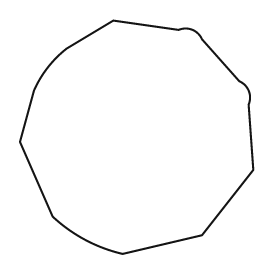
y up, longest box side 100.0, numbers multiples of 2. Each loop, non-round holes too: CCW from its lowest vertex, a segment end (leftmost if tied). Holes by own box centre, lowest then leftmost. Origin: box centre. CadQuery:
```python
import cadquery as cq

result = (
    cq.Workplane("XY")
    .moveTo(-6.0, -50.0)
    .lineTo(28.0, -42.0)
    .lineTo(50.0, -14.0)
    .lineTo(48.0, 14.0)
    .threePointArc((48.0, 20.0), (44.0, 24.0))
    .lineTo(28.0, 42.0)
    .threePointArc((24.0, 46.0), (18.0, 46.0))
    .lineTo(-10.0, 50.0)
    .lineTo(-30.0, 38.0)
    .threePointArc((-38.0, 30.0), (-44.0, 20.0))
    .lineTo(-50.0, -2.0)
    .lineTo(-36.0, -34.0)
    .threePointArc((-22.0, -44.0), (-6.0, -50.0))
    .close()
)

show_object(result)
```